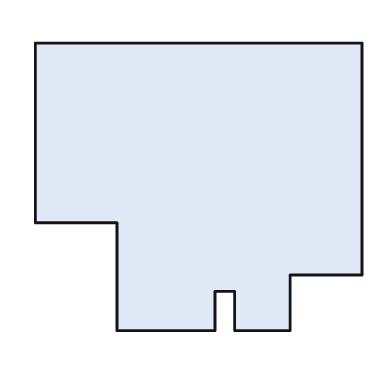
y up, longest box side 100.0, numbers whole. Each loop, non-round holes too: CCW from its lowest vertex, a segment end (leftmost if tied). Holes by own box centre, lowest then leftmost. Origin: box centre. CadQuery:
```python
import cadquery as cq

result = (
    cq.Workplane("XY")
    .moveTo(-25.0, -44.0)
    .lineTo(5.0, -44.0)
    .lineTo(5.0, -32.0)
    .lineTo(11.0, -32.0)
    .lineTo(11.0, -44.0)
    .lineTo(28.0, -44.0)
    .lineTo(28.0, -27.0)
    .lineTo(50.0, -27.0)
    .lineTo(50.0, 44.0)
    .lineTo(-50.0, 44.0)
    .lineTo(-50.0, -11.0)
    .lineTo(-25.0, -11.0)
    .close()
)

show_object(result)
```